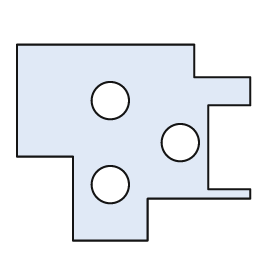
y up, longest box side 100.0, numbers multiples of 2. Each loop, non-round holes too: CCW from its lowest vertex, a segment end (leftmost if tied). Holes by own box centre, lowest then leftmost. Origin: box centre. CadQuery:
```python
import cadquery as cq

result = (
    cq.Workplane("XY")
    .moveTo(-26.0, -42.0)
    .lineTo(6.0, -42.0)
    .lineTo(6.0, -24.0)
    .lineTo(50.0, -24.0)
    .lineTo(50.0, -20.0)
    .lineTo(32.0, -20.0)
    .lineTo(32.0, 16.0)
    .lineTo(50.0, 16.0)
    .lineTo(50.0, 28.0)
    .lineTo(26.0, 28.0)
    .lineTo(26.0, 42.0)
    .lineTo(-50.0, 42.0)
    .lineTo(-50.0, -6.0)
    .lineTo(-26.0, -6.0)
    .close()
    .moveTo(-10.0, -18.0)
    .circle(8.0)
    .moveTo(20.0, 0.0)
    .circle(8.0)
    .moveTo(-10.0, 18.0)
    .circle(8.0)
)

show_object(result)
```